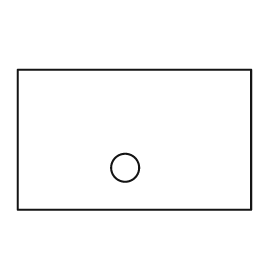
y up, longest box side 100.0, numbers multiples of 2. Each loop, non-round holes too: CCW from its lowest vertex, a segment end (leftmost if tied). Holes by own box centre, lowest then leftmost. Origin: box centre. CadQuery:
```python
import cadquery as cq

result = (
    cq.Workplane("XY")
    .moveTo(-50.0, -30.0)
    .lineTo(50.0, -30.0)
    .lineTo(50.0, 30.0)
    .lineTo(-50.0, 30.0)
    .close()
    .moveTo(-4.0, -12.0)
    .circle(6.0)
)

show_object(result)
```